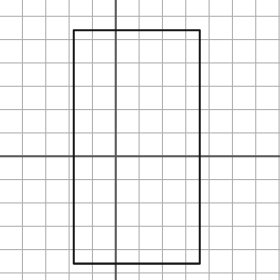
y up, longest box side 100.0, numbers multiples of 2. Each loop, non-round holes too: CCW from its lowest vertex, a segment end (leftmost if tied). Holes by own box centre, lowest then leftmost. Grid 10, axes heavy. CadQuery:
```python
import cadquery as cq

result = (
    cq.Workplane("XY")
    .moveTo(-18.0, -46.0)
    .lineTo(36.0, -46.0)
    .lineTo(36.0, 54.0)
    .lineTo(-18.0, 54.0)
    .close()
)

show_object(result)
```